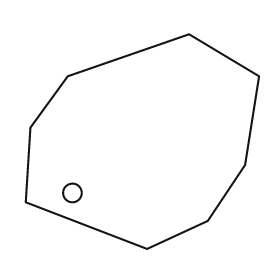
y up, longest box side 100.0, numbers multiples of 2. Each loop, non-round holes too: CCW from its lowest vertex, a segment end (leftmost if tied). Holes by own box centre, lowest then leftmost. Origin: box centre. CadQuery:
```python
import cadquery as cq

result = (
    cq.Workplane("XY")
    .moveTo(2.0, -46.0)
    .lineTo(28.0, -34.0)
    .lineTo(44.0, -10.0)
    .lineTo(50.0, 28.0)
    .lineTo(20.0, 46.0)
    .lineTo(-32.0, 28.0)
    .lineTo(-48.0, 6.0)
    .lineTo(-50.0, -26.0)
    .close()
    .moveTo(-30.0, -22.0)
    .circle(4.0)
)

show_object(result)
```